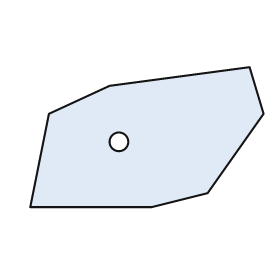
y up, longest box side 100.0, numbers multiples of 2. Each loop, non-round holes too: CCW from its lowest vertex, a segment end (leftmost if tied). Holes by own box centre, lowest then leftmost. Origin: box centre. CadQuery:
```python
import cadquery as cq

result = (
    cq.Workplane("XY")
    .moveTo(-50.0, -30.0)
    .lineTo(2.0, -30.0)
    .lineTo(26.0, -24.0)
    .lineTo(50.0, 10.0)
    .lineTo(44.0, 30.0)
    .lineTo(-16.0, 22.0)
    .lineTo(-42.0, 10.0)
    .close()
    .moveTo(-12.0, -2.0)
    .circle(4.0)
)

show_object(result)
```